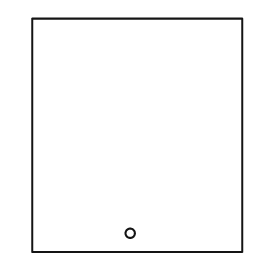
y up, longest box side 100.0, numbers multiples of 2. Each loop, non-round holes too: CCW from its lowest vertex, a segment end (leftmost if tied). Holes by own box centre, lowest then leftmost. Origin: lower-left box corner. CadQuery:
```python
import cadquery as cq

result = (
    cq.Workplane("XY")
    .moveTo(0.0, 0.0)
    .lineTo(90.0, 0.0)
    .lineTo(90.0, 100.0)
    .lineTo(0.0, 100.0)
    .close()
    .moveTo(42.0, 8.0)
    .circle(2.0)
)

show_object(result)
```